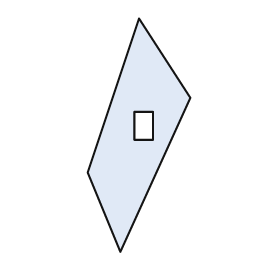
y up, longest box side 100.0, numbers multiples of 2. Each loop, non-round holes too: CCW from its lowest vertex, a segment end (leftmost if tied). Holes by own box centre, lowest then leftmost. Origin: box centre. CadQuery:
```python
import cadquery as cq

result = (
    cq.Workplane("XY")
    .moveTo(-8.0, -50.0)
    .lineTo(22.0, 16.0)
    .lineTo(0.0, 50.0)
    .lineTo(-22.0, -16.0)
    .close()
    .moveTo(-2.0, -2.0)
    .lineTo(6.0, -2.0)
    .lineTo(6.0, 10.0)
    .lineTo(-2.0, 10.0)
    .close()
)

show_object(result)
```